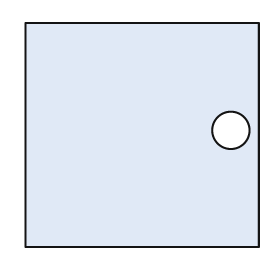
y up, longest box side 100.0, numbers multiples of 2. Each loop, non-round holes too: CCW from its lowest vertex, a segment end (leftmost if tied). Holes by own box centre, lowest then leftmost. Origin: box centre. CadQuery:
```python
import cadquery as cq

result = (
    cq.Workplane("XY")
    .moveTo(-50.0, -48.0)
    .lineTo(50.0, -48.0)
    .lineTo(50.0, 48.0)
    .lineTo(-50.0, 48.0)
    .close()
    .moveTo(38.0, 2.0)
    .circle(8.0)
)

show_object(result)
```